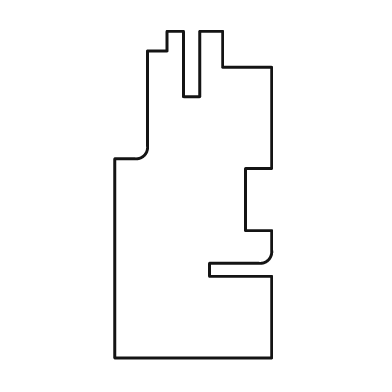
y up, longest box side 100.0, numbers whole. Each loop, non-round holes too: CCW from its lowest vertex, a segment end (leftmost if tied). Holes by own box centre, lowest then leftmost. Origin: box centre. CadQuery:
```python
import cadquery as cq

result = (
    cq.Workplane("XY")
    .moveTo(-24.0, -50.0)
    .lineTo(24.0, -50.0)
    .lineTo(24.0, -25.0)
    .lineTo(5.0, -25.0)
    .lineTo(5.0, -21.0)
    .lineTo(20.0, -21.0)
    .threePointArc((23.0, -20.0), (24.0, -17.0))
    .lineTo(24.0, -11.0)
    .lineTo(16.0, -11.0)
    .lineTo(16.0, 8.0)
    .lineTo(24.0, 8.0)
    .lineTo(24.0, 39.0)
    .lineTo(9.0, 39.0)
    .lineTo(9.0, 50.0)
    .lineTo(2.0, 50.0)
    .lineTo(2.0, 30.0)
    .lineTo(-3.0, 30.0)
    .lineTo(-3.0, 50.0)
    .lineTo(-8.0, 50.0)
    .lineTo(-8.0, 44.0)
    .lineTo(-14.0, 44.0)
    .lineTo(-14.0, 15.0)
    .threePointArc((-15.0, 12.0), (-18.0, 11.0))
    .lineTo(-24.0, 11.0)
    .close()
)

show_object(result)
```